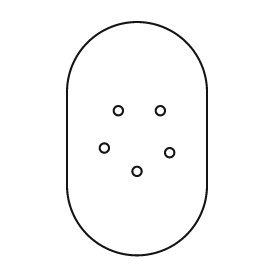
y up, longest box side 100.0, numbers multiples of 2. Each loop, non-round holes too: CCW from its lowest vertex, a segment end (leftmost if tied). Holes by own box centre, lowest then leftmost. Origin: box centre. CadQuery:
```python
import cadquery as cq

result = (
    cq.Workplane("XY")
    .moveTo(-30.0, -20.0)
    .threePointArc((0.0, -50.0), (30.0, -20.0))
    .lineTo(30.0, 20.0)
    .threePointArc((0.0, 50.0), (-30.0, 20.0))
    .close()
    .moveTo(0.0, -14.0)
    .circle(2.0)
    .moveTo(14.0, -6.0)
    .circle(2.0)
    .moveTo(-14.0, -4.0)
    .circle(2.0)
    .moveTo(-8.0, 12.0)
    .circle(2.0)
    .moveTo(10.0, 12.0)
    .circle(2.0)
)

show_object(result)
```